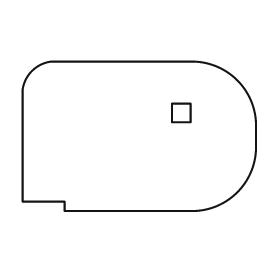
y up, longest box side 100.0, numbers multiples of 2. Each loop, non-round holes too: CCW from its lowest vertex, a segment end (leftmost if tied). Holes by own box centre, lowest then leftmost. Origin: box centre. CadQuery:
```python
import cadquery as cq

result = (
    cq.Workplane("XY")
    .moveTo(-32.0, -32.0)
    .lineTo(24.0, -32.0)
    .threePointArc((42.0, -24.0), (50.0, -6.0))
    .lineTo(50.0, 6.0)
    .threePointArc((42.0, 24.0), (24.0, 32.0))
    .lineTo(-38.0, 32.0)
    .threePointArc((-46.0, 28.0), (-50.0, 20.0))
    .lineTo(-50.0, -28.0)
    .lineTo(-32.0, -28.0)
    .close()
    .moveTo(14.0, 6.0)
    .lineTo(22.0, 6.0)
    .lineTo(22.0, 14.0)
    .lineTo(14.0, 14.0)
    .close()
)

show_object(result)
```